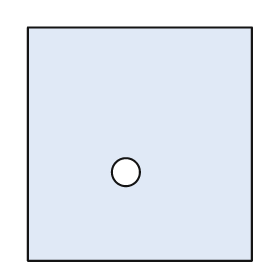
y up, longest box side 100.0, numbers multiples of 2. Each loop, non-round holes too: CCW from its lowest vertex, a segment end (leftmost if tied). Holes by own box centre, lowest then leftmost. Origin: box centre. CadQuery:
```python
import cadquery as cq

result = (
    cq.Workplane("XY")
    .moveTo(-48.0, -50.0)
    .lineTo(48.0, -50.0)
    .lineTo(48.0, 50.0)
    .lineTo(-48.0, 50.0)
    .close()
    .moveTo(-6.0, -12.0)
    .circle(6.0)
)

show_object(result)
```